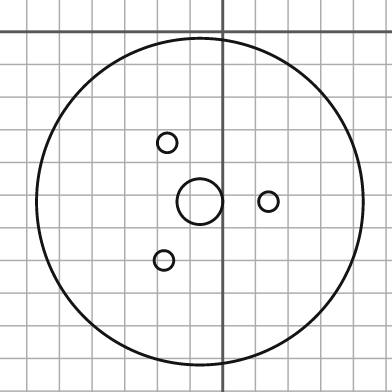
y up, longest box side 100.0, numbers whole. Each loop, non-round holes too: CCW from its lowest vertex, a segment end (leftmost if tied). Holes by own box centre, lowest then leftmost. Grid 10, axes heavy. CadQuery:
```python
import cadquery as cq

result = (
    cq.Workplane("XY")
    .moveTo(-7.0, -52.0)
    .circle(50.0)
    .moveTo(-18.0, -70.0)
    .circle(3.0)
    .moveTo(-7.0, -52.0)
    .circle(7.0)
    .moveTo(14.0, -52.0)
    .circle(3.0)
    .moveTo(-17.0, -34.0)
    .circle(3.0)
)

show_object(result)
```